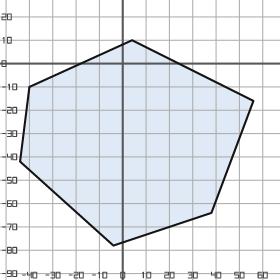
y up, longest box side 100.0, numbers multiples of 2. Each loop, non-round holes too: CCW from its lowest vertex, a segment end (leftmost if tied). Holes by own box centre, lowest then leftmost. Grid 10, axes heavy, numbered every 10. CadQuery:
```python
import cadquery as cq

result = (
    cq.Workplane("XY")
    .moveTo(-4.0, -78.0)
    .lineTo(38.0, -64.0)
    .lineTo(56.0, -16.0)
    .lineTo(4.0, 10.0)
    .lineTo(-40.0, -10.0)
    .lineTo(-44.0, -42.0)
    .close()
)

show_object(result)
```